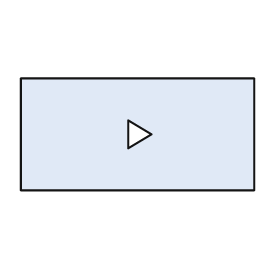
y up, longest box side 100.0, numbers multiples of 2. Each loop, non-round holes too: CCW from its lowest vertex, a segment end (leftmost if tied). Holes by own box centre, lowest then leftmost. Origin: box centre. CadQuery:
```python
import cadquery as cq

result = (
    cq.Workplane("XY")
    .moveTo(-50.0, -24.0)
    .lineTo(50.0, -24.0)
    .lineTo(50.0, 24.0)
    .lineTo(-50.0, 24.0)
    .close()
    .moveTo(-4.0, -6.0)
    .lineTo(6.0, 0.0)
    .lineTo(-4.0, 6.0)
    .close()
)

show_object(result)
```